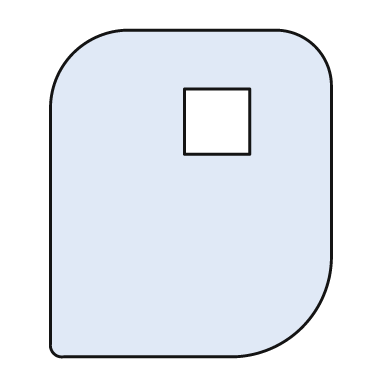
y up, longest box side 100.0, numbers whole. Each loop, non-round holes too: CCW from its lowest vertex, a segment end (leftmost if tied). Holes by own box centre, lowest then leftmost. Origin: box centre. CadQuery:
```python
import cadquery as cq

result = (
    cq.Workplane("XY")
    .moveTo(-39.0, -50.0)
    .lineTo(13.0, -50.0)
    .threePointArc((34.0, -41.0), (43.0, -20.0))
    .lineTo(43.0, 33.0)
    .threePointArc((38.0, 45.0), (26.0, 50.0))
    .lineTo(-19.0, 50.0)
    .threePointArc((-36.0, 43.0), (-43.0, 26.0))
    .lineTo(-43.0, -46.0)
    .threePointArc((-42.0, -49.0), (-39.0, -50.0))
    .close()
    .moveTo(-2.0, 12.0)
    .lineTo(18.0, 12.0)
    .lineTo(18.0, 32.0)
    .lineTo(-2.0, 32.0)
    .close()
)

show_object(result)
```